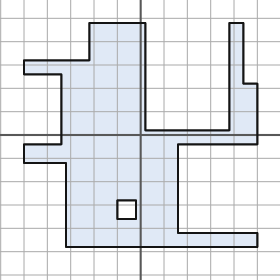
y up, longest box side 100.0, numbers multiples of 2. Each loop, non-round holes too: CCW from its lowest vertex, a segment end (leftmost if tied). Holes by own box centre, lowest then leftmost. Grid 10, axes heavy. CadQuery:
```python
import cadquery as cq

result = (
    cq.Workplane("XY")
    .moveTo(-32.0, -48.0)
    .lineTo(50.0, -48.0)
    .lineTo(50.0, -42.0)
    .lineTo(16.0, -42.0)
    .lineTo(16.0, -4.0)
    .lineTo(50.0, -4.0)
    .lineTo(50.0, 22.0)
    .lineTo(44.0, 22.0)
    .lineTo(44.0, 48.0)
    .lineTo(38.0, 48.0)
    .lineTo(38.0, 2.0)
    .lineTo(2.0, 2.0)
    .lineTo(2.0, 48.0)
    .lineTo(-22.0, 48.0)
    .lineTo(-22.0, 32.0)
    .lineTo(-50.0, 32.0)
    .lineTo(-50.0, 26.0)
    .lineTo(-34.0, 26.0)
    .lineTo(-34.0, -4.0)
    .lineTo(-50.0, -4.0)
    .lineTo(-50.0, -12.0)
    .lineTo(-32.0, -12.0)
    .close()
    .moveTo(-10.0, -36.0)
    .lineTo(-2.0, -36.0)
    .lineTo(-2.0, -28.0)
    .lineTo(-10.0, -28.0)
    .close()
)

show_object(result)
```